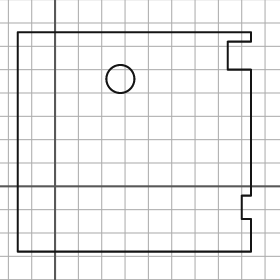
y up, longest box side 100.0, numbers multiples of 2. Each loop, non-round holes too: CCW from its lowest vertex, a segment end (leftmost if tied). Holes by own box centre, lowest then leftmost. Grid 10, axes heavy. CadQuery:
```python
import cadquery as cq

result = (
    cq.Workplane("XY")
    .moveTo(-16.0, -28.0)
    .lineTo(84.0, -28.0)
    .lineTo(84.0, -14.0)
    .lineTo(80.0, -14.0)
    .lineTo(80.0, -4.0)
    .lineTo(84.0, -4.0)
    .lineTo(84.0, 50.0)
    .lineTo(74.0, 50.0)
    .lineTo(74.0, 62.0)
    .lineTo(84.0, 62.0)
    .lineTo(84.0, 66.0)
    .lineTo(-16.0, 66.0)
    .close()
    .moveTo(28.0, 46.0)
    .circle(6.0)
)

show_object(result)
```